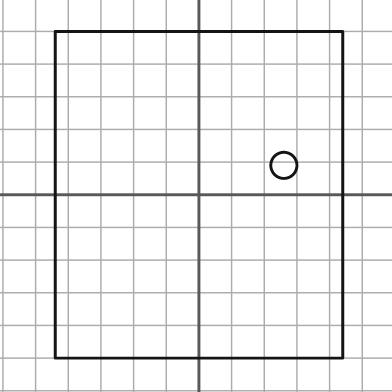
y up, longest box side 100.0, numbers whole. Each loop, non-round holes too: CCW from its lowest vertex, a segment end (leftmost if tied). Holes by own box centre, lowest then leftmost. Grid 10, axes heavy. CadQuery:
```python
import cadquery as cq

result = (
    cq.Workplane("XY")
    .moveTo(-44.0, -50.0)
    .lineTo(44.0, -50.0)
    .lineTo(44.0, 50.0)
    .lineTo(-44.0, 50.0)
    .close()
    .moveTo(26.0, 9.0)
    .circle(4.0)
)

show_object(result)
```